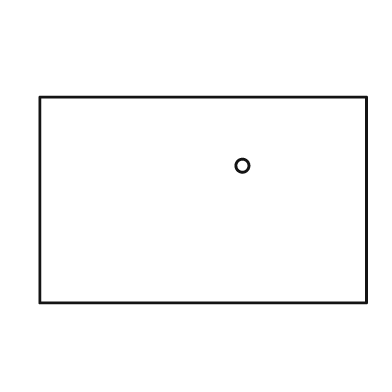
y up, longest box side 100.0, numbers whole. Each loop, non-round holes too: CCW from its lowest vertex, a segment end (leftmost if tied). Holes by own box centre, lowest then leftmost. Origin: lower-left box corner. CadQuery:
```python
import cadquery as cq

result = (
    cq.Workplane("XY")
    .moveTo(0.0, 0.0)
    .lineTo(100.0, 0.0)
    .lineTo(100.0, 63.0)
    .lineTo(0.0, 63.0)
    .close()
    .moveTo(62.0, 42.0)
    .circle(2.0)
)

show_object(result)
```